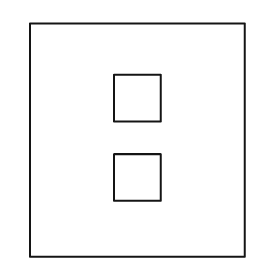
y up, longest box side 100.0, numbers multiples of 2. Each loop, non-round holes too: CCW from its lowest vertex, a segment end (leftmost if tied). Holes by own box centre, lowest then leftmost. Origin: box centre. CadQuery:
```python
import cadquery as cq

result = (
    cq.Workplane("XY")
    .moveTo(-46.0, -50.0)
    .lineTo(46.0, -50.0)
    .lineTo(46.0, 50.0)
    .lineTo(-46.0, 50.0)
    .close()
    .moveTo(-10.0, -26.0)
    .lineTo(10.0, -26.0)
    .lineTo(10.0, -6.0)
    .lineTo(-10.0, -6.0)
    .close()
    .moveTo(-10.0, 8.0)
    .lineTo(10.0, 8.0)
    .lineTo(10.0, 28.0)
    .lineTo(-10.0, 28.0)
    .close()
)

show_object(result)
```